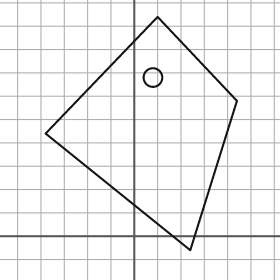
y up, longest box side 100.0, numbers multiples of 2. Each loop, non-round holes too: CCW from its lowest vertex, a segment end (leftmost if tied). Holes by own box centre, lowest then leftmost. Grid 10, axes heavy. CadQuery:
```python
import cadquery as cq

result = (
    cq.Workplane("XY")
    .moveTo(24.0, -6.0)
    .lineTo(44.0, 58.0)
    .lineTo(10.0, 94.0)
    .lineTo(-38.0, 44.0)
    .close()
    .moveTo(8.0, 68.0)
    .circle(4.0)
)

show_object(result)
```